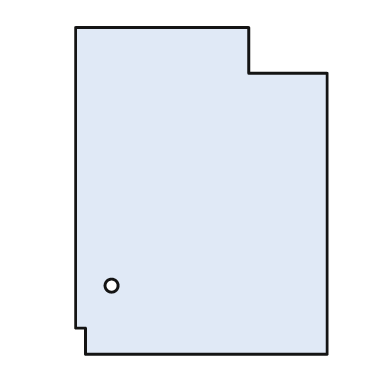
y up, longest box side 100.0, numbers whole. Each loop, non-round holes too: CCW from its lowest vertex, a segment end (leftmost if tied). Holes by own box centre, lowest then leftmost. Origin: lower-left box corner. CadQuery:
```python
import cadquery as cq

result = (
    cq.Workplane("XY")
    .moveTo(3.0, 0.0)
    .lineTo(77.0, 0.0)
    .lineTo(77.0, 86.0)
    .lineTo(53.0, 86.0)
    .lineTo(53.0, 100.0)
    .lineTo(0.0, 100.0)
    .lineTo(0.0, 8.0)
    .lineTo(3.0, 8.0)
    .close()
    .moveTo(11.0, 21.0)
    .circle(2.0)
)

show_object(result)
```